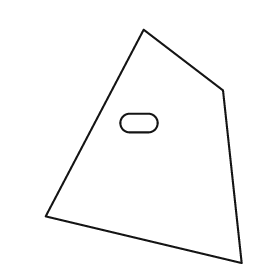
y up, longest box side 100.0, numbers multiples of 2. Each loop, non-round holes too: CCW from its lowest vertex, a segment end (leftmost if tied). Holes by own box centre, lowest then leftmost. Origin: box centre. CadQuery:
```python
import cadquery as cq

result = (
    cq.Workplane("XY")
    .moveTo(42.0, -50.0)
    .lineTo(34.0, 24.0)
    .lineTo(0.0, 50.0)
    .lineTo(-42.0, -30.0)
    .close()
    .moveTo(-6.0, 6.0)
    .lineTo(2.0, 6.0)
    .threePointArc((6.0, 10.0), (2.0, 14.0))
    .lineTo(-6.0, 14.0)
    .threePointArc((-10.0, 10.0), (-6.0, 6.0))
    .close()
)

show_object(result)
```